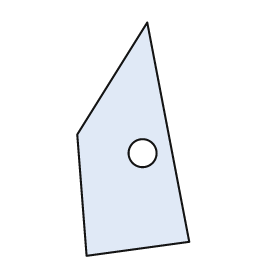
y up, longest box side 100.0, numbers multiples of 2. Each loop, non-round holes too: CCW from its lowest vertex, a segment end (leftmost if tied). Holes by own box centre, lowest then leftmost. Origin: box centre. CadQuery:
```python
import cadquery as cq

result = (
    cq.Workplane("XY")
    .moveTo(-20.0, -50.0)
    .lineTo(24.0, -44.0)
    .lineTo(6.0, 50.0)
    .lineTo(-24.0, 2.0)
    .close()
    .moveTo(4.0, -6.0)
    .circle(6.0)
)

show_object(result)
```